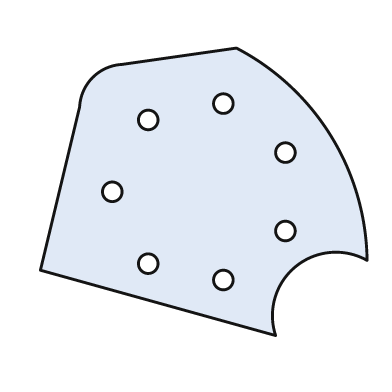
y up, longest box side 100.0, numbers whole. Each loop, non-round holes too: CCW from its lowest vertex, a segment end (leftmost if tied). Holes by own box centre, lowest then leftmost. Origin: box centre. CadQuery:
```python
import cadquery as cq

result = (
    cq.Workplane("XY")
    .moveTo(22.0, -44.0)
    .threePointArc((28.0, -23.0), (50.0, -21.0))
    .threePointArc((39.0, 17.0), (10.0, 44.0))
    .lineTo(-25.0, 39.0)
    .threePointArc((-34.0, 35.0), (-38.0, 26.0))
    .lineTo(-50.0, -24.0)
    .close()
    .moveTo(6.0, -27.0)
    .circle(3.0)
    .moveTo(-17.0, -22.0)
    .circle(3.0)
    .moveTo(25.0, -12.0)
    .circle(3.0)
    .moveTo(-28.0, 0.0)
    .circle(3.0)
    .moveTo(25.0, 12.0)
    .circle(3.0)
    .moveTo(-17.0, 22.0)
    .circle(3.0)
    .moveTo(6.0, 27.0)
    .circle(3.0)
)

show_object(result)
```